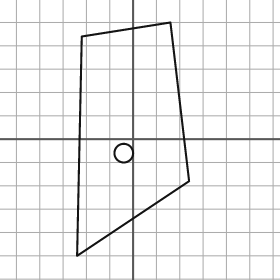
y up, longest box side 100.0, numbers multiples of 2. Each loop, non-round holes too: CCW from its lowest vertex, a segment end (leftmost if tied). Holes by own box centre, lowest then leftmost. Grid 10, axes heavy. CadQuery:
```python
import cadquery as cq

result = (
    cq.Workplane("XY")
    .moveTo(-24.0, -50.0)
    .lineTo(24.0, -18.0)
    .lineTo(16.0, 50.0)
    .lineTo(-22.0, 44.0)
    .close()
    .moveTo(-4.0, -6.0)
    .circle(4.0)
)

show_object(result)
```